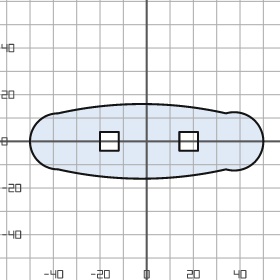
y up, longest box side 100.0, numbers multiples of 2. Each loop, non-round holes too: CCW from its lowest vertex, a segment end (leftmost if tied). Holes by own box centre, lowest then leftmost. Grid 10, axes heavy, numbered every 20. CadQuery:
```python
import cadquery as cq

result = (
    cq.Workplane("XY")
    .moveTo(-38.0, -12.0)
    .threePointArc((-2.0, -16.0), (34.0, -12.0))
    .threePointArc((50.0, 0.0), (34.0, 12.0))
    .threePointArc((-2.0, 16.0), (-38.0, 12.0))
    .threePointArc((-50.0, 0.0), (-38.0, -12.0))
    .close()
    .moveTo(-20.0, -4.0)
    .lineTo(-12.0, -4.0)
    .lineTo(-12.0, 4.0)
    .lineTo(-20.0, 4.0)
    .close()
    .moveTo(14.0, -4.0)
    .lineTo(22.0, -4.0)
    .lineTo(22.0, 4.0)
    .lineTo(14.0, 4.0)
    .close()
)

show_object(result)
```